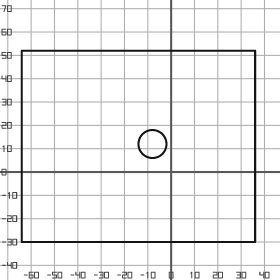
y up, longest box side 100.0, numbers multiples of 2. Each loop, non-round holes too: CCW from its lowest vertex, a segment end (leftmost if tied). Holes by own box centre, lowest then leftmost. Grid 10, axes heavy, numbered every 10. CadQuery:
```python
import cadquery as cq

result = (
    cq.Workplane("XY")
    .moveTo(-64.0, -30.0)
    .lineTo(36.0, -30.0)
    .lineTo(36.0, 52.0)
    .lineTo(-64.0, 52.0)
    .close()
    .moveTo(-8.0, 12.0)
    .circle(6.0)
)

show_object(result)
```